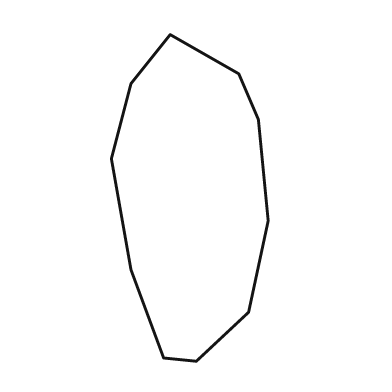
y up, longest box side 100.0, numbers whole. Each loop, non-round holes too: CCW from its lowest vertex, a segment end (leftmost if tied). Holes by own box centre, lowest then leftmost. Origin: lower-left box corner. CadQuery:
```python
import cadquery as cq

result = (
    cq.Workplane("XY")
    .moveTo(26.0, 0.0)
    .lineTo(42.0, 15.0)
    .lineTo(48.0, 43.0)
    .lineTo(45.0, 74.0)
    .lineTo(39.0, 88.0)
    .lineTo(18.0, 100.0)
    .lineTo(6.0, 85.0)
    .lineTo(0.0, 62.0)
    .lineTo(6.0, 28.0)
    .lineTo(16.0, 1.0)
    .close()
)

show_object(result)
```